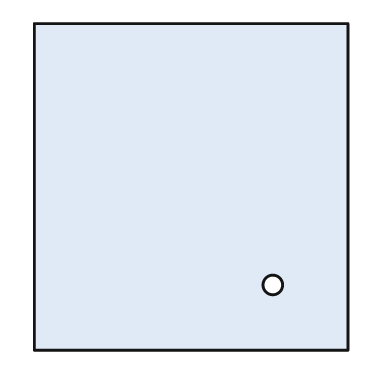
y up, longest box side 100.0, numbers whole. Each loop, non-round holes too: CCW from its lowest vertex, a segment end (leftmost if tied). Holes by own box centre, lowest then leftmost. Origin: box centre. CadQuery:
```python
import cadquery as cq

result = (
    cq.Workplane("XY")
    .moveTo(-48.0, -50.0)
    .lineTo(48.0, -50.0)
    .lineTo(48.0, 50.0)
    .lineTo(-48.0, 50.0)
    .close()
    .moveTo(25.0, -30.0)
    .circle(3.0)
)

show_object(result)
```